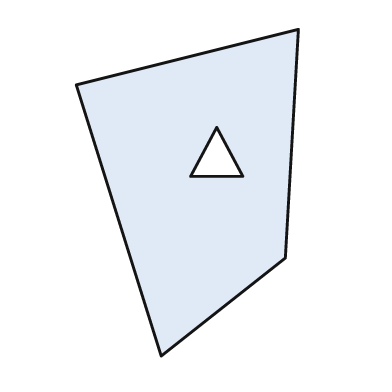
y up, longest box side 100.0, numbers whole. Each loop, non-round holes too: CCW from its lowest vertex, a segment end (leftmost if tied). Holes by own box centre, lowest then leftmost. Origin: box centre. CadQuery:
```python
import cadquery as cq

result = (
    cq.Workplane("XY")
    .moveTo(-8.0, -50.0)
    .lineTo(30.0, -20.0)
    .lineTo(34.0, 50.0)
    .lineTo(-34.0, 33.0)
    .close()
    .moveTo(1.0, 5.0)
    .lineTo(17.0, 5.0)
    .lineTo(9.0, 20.0)
    .close()
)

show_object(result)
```